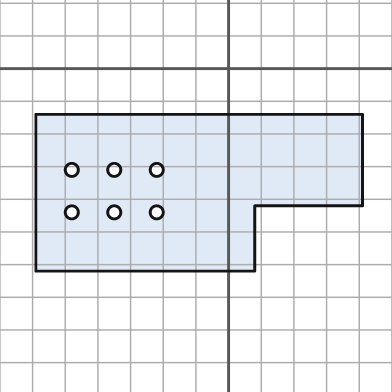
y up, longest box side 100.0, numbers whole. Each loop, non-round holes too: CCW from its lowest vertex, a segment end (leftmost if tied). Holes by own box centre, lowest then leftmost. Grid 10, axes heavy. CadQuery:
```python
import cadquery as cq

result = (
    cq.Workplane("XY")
    .moveTo(-59.0, -62.0)
    .lineTo(8.0, -62.0)
    .lineTo(8.0, -42.0)
    .lineTo(41.0, -42.0)
    .lineTo(41.0, -14.0)
    .lineTo(-59.0, -14.0)
    .close()
    .moveTo(-48.0, -44.0)
    .circle(2.0)
    .moveTo(-35.0, -44.0)
    .circle(2.0)
    .moveTo(-22.0, -44.0)
    .circle(2.0)
    .moveTo(-48.0, -31.0)
    .circle(2.0)
    .moveTo(-35.0, -31.0)
    .circle(2.0)
    .moveTo(-22.0, -31.0)
    .circle(2.0)
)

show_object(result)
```